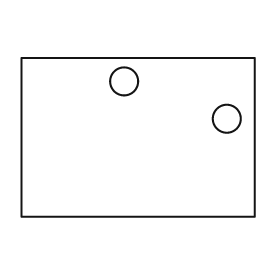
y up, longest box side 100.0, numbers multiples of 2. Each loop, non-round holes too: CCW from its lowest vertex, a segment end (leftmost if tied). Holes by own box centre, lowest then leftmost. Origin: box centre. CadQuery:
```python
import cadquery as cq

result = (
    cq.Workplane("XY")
    .moveTo(-50.0, -34.0)
    .lineTo(50.0, -34.0)
    .lineTo(50.0, 34.0)
    .lineTo(-50.0, 34.0)
    .close()
    .moveTo(38.0, 8.0)
    .circle(6.0)
    .moveTo(-6.0, 24.0)
    .circle(6.0)
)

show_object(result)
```